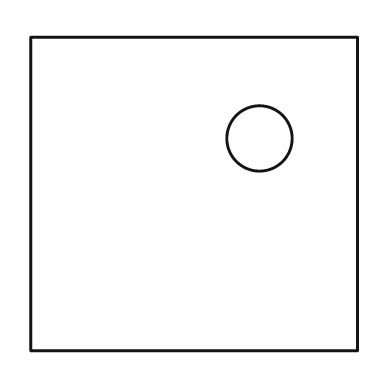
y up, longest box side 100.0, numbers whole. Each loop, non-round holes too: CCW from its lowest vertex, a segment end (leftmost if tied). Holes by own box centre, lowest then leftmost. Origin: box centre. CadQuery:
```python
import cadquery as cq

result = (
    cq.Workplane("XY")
    .moveTo(-50.0, -48.0)
    .lineTo(50.0, -48.0)
    .lineTo(50.0, 48.0)
    .lineTo(-50.0, 48.0)
    .close()
    .moveTo(20.0, 17.0)
    .circle(10.0)
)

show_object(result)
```